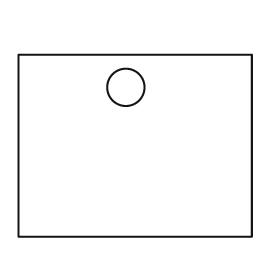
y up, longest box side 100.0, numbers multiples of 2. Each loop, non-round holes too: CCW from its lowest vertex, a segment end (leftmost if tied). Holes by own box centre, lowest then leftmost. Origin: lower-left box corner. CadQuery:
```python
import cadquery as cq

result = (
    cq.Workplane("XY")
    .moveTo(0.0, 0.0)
    .lineTo(100.0, 0.0)
    .lineTo(100.0, 78.0)
    .lineTo(0.0, 78.0)
    .close()
    .moveTo(46.0, 64.0)
    .circle(8.0)
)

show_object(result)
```